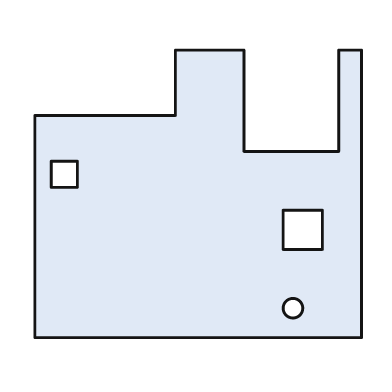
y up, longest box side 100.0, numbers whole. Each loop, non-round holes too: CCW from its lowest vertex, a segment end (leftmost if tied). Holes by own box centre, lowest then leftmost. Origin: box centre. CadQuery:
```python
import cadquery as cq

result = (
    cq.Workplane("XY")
    .moveTo(-50.0, -44.0)
    .lineTo(50.0, -44.0)
    .lineTo(50.0, 44.0)
    .lineTo(43.0, 44.0)
    .lineTo(43.0, 13.0)
    .lineTo(14.0, 13.0)
    .lineTo(14.0, 44.0)
    .lineTo(-7.0, 44.0)
    .lineTo(-7.0, 24.0)
    .lineTo(-50.0, 24.0)
    .close()
    .moveTo(29.0, -35.0)
    .circle(3.0)
    .moveTo(26.0, -17.0)
    .lineTo(38.0, -17.0)
    .lineTo(38.0, -5.0)
    .lineTo(26.0, -5.0)
    .close()
    .moveTo(-45.0, 2.0)
    .lineTo(-37.0, 2.0)
    .lineTo(-37.0, 10.0)
    .lineTo(-45.0, 10.0)
    .close()
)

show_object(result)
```